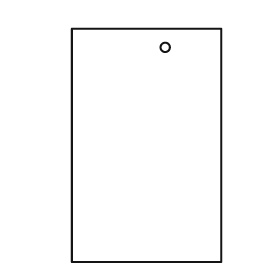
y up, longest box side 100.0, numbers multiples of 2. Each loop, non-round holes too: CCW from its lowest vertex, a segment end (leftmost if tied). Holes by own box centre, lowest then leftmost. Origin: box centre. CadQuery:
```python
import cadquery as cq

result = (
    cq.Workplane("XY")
    .moveTo(-32.0, -50.0)
    .lineTo(32.0, -50.0)
    .lineTo(32.0, 50.0)
    .lineTo(-32.0, 50.0)
    .close()
    .moveTo(8.0, 42.0)
    .circle(2.0)
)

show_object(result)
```